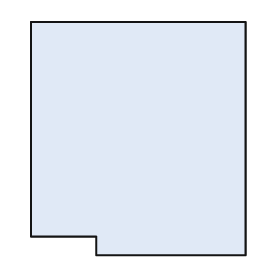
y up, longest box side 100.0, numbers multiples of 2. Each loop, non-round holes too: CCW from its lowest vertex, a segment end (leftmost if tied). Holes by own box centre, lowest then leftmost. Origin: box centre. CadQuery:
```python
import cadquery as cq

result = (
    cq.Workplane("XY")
    .moveTo(-18.0, -50.0)
    .lineTo(46.0, -50.0)
    .lineTo(46.0, 50.0)
    .lineTo(-46.0, 50.0)
    .lineTo(-46.0, -42.0)
    .lineTo(-18.0, -42.0)
    .close()
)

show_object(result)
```